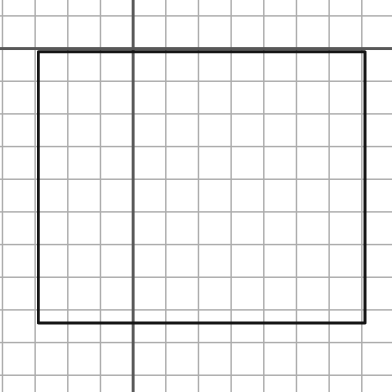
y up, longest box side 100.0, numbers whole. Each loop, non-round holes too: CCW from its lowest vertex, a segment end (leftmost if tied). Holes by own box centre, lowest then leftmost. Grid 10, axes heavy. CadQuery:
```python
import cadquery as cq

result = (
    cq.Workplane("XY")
    .moveTo(-29.0, -84.0)
    .lineTo(71.0, -84.0)
    .lineTo(71.0, -1.0)
    .lineTo(-29.0, -1.0)
    .close()
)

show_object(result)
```